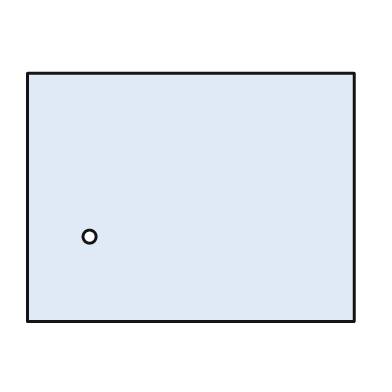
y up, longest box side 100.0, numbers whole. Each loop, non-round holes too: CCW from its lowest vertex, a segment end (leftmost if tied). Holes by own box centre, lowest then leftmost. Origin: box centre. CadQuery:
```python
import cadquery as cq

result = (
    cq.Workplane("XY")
    .moveTo(-50.0, -38.0)
    .lineTo(50.0, -38.0)
    .lineTo(50.0, 38.0)
    .lineTo(-50.0, 38.0)
    .close()
    .moveTo(-31.0, -12.0)
    .circle(2.0)
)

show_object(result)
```